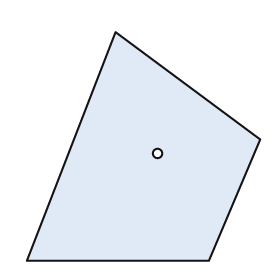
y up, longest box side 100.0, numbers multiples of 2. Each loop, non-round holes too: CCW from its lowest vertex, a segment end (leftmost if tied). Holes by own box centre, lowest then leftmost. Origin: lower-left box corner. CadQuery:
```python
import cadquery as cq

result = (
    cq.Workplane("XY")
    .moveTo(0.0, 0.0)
    .lineTo(78.0, 0.0)
    .lineTo(100.0, 52.0)
    .lineTo(38.0, 98.0)
    .close()
    .moveTo(56.0, 46.0)
    .circle(2.0)
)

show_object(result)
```